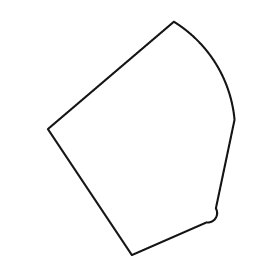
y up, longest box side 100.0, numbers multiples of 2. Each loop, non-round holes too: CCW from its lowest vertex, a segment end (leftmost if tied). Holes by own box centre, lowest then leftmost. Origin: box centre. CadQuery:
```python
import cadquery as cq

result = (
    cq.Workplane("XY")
    .moveTo(-4.0, -50.0)
    .lineTo(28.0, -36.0)
    .threePointArc((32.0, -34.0), (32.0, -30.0))
    .lineTo(40.0, 8.0)
    .threePointArc((32.0, 32.0), (14.0, 50.0))
    .lineTo(-40.0, 4.0)
    .close()
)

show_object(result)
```